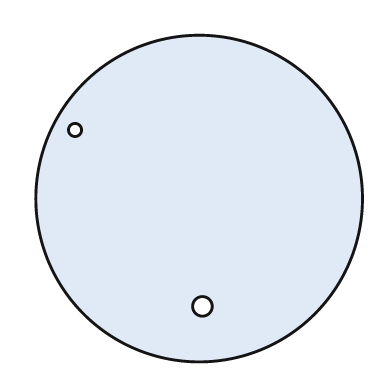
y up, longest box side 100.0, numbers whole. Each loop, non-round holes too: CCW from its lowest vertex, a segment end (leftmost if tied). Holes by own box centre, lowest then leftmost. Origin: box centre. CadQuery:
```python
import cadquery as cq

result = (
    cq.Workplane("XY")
    .moveTo(0.0, 0.0)
    .circle(50.0)
    .moveTo(1.0, -33.0)
    .circle(3.0)
    .moveTo(-38.0, 21.0)
    .circle(2.0)
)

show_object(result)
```